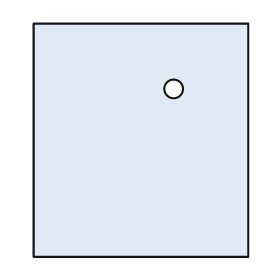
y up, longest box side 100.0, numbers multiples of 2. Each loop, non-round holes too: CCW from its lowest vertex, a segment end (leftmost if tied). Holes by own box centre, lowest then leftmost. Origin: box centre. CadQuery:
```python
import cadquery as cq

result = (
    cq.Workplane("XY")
    .moveTo(-46.0, -50.0)
    .lineTo(46.0, -50.0)
    .lineTo(46.0, 50.0)
    .lineTo(-46.0, 50.0)
    .close()
    .moveTo(14.0, 22.0)
    .circle(4.0)
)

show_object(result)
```